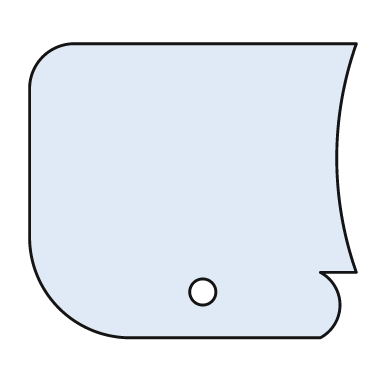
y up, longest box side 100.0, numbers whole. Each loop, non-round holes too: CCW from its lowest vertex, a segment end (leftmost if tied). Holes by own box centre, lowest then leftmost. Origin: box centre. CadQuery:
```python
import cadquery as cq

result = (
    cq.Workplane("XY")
    .moveTo(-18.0, -45.0)
    .lineTo(39.0, -45.0)
    .threePointArc((45.0, -35.0), (39.0, -25.0))
    .lineTo(50.0, -25.0)
    .threePointArc((44.0, 10.0), (50.0, 45.0))
    .lineTo(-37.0, 45.0)
    .threePointArc((-46.0, 41.0), (-50.0, 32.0))
    .lineTo(-50.0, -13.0)
    .threePointArc((-41.0, -36.0), (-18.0, -45.0))
    .close()
    .moveTo(3.0, -31.0)
    .circle(4.0)
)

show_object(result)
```